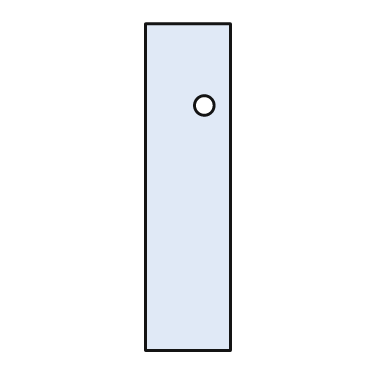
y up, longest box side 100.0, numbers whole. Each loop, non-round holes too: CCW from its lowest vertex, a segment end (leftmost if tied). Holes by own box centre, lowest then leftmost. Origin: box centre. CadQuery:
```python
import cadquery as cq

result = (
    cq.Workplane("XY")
    .moveTo(-13.0, -50.0)
    .lineTo(13.0, -50.0)
    .lineTo(13.0, 50.0)
    .lineTo(-13.0, 50.0)
    .close()
    .moveTo(5.0, 25.0)
    .circle(3.0)
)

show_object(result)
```